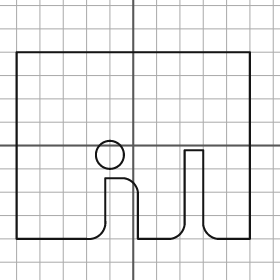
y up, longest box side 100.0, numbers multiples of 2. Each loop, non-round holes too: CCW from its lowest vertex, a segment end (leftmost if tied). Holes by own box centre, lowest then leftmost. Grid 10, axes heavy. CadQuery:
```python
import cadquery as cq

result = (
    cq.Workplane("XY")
    .moveTo(-50.0, -40.0)
    .lineTo(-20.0, -40.0)
    .threePointArc((-14.0, -38.0), (-12.0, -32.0))
    .lineTo(-12.0, -14.0)
    .lineTo(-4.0, -14.0)
    .threePointArc((0.0, -16.0), (2.0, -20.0))
    .lineTo(2.0, -40.0)
    .lineTo(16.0, -40.0)
    .threePointArc((20.0, -38.0), (22.0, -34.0))
    .lineTo(22.0, -2.0)
    .lineTo(30.0, -2.0)
    .lineTo(30.0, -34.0)
    .threePointArc((32.0, -38.0), (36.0, -40.0))
    .lineTo(50.0, -40.0)
    .lineTo(50.0, 40.0)
    .lineTo(-50.0, 40.0)
    .close()
    .moveTo(-10.0, -4.0)
    .circle(6.0)
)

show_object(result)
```